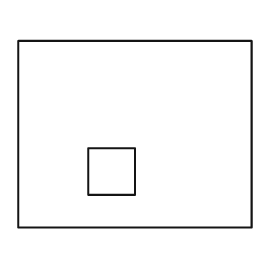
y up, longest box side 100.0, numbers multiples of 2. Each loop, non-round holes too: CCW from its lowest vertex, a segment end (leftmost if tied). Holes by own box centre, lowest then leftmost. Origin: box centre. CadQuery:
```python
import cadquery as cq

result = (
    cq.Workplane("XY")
    .moveTo(-50.0, -40.0)
    .lineTo(50.0, -40.0)
    .lineTo(50.0, 40.0)
    .lineTo(-50.0, 40.0)
    .close()
    .moveTo(-20.0, -26.0)
    .lineTo(0.0, -26.0)
    .lineTo(0.0, -6.0)
    .lineTo(-20.0, -6.0)
    .close()
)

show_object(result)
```